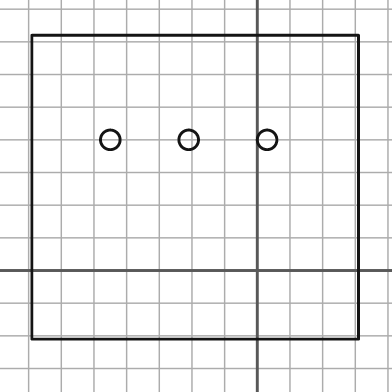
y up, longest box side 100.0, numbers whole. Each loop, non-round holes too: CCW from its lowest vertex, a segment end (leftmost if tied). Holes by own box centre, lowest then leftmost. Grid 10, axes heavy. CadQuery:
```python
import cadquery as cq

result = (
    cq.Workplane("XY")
    .moveTo(-69.0, -21.0)
    .lineTo(31.0, -21.0)
    .lineTo(31.0, 72.0)
    .lineTo(-69.0, 72.0)
    .close()
    .moveTo(-45.0, 40.0)
    .circle(3.0)
    .moveTo(-21.0, 40.0)
    .circle(3.0)
    .moveTo(3.0, 40.0)
    .circle(3.0)
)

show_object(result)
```